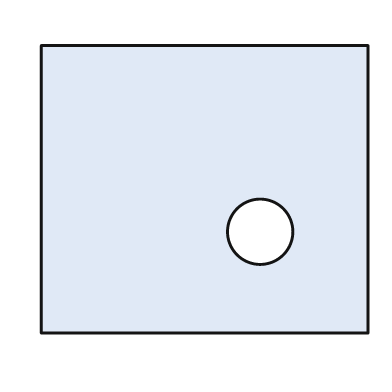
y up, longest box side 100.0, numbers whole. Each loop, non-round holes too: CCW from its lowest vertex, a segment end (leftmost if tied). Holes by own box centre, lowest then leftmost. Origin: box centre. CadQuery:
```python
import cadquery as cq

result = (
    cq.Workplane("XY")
    .moveTo(-50.0, -44.0)
    .lineTo(50.0, -44.0)
    .lineTo(50.0, 44.0)
    .lineTo(-50.0, 44.0)
    .close()
    .moveTo(17.0, -13.0)
    .circle(10.0)
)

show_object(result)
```